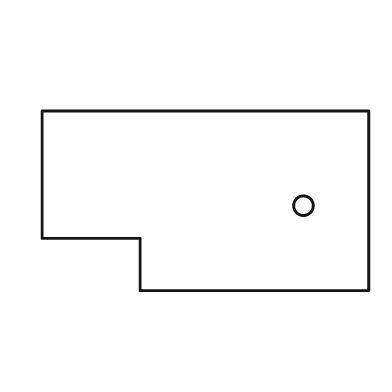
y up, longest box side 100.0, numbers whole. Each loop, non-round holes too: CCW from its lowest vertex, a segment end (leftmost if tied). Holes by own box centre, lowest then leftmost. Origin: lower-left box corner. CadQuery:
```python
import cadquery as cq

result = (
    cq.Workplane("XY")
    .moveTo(30.0, 0.0)
    .lineTo(100.0, 0.0)
    .lineTo(100.0, 55.0)
    .lineTo(0.0, 55.0)
    .lineTo(0.0, 16.0)
    .lineTo(30.0, 16.0)
    .close()
    .moveTo(80.0, 26.0)
    .circle(3.0)
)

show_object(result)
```